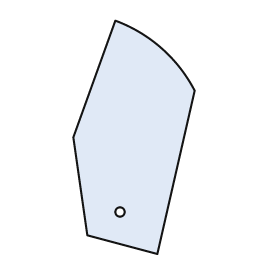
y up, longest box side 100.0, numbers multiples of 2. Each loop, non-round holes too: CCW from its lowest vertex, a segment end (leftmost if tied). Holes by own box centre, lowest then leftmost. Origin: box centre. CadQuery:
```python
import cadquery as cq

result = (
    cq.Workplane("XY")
    .moveTo(10.0, -50.0)
    .lineTo(26.0, 20.0)
    .threePointArc((12.0, 38.0), (-8.0, 50.0))
    .lineTo(-26.0, 0.0)
    .lineTo(-20.0, -42.0)
    .close()
    .moveTo(-6.0, -32.0)
    .circle(2.0)
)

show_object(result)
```